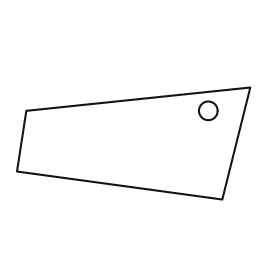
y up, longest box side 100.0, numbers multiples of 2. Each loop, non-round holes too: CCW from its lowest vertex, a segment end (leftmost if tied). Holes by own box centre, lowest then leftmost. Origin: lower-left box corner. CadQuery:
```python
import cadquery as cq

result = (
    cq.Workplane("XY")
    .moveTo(88.0, 0.0)
    .lineTo(100.0, 48.0)
    .lineTo(4.0, 38.0)
    .lineTo(0.0, 12.0)
    .close()
    .moveTo(82.0, 38.0)
    .circle(4.0)
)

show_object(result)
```